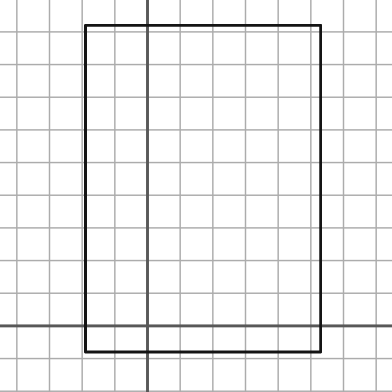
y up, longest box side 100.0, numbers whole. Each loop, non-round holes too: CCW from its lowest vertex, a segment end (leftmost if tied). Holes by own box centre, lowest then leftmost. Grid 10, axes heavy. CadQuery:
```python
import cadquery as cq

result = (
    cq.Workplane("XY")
    .moveTo(-19.0, -8.0)
    .lineTo(53.0, -8.0)
    .lineTo(53.0, 92.0)
    .lineTo(-19.0, 92.0)
    .close()
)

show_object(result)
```